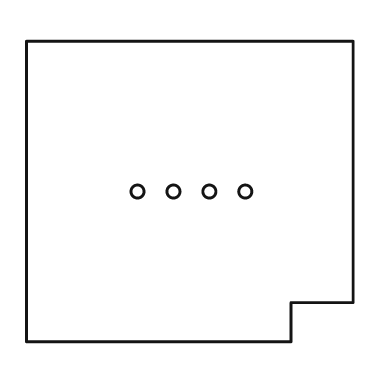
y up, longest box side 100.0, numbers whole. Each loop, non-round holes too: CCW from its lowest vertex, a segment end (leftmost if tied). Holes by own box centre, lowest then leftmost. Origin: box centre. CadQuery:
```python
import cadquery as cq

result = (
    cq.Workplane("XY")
    .moveTo(-50.0, -46.0)
    .lineTo(31.0, -46.0)
    .lineTo(31.0, -34.0)
    .lineTo(50.0, -34.0)
    .lineTo(50.0, 46.0)
    .lineTo(-50.0, 46.0)
    .close()
    .moveTo(-16.0, 0.0)
    .circle(2.0)
    .moveTo(-5.0, 0.0)
    .circle(2.0)
    .moveTo(6.0, 0.0)
    .circle(2.0)
    .moveTo(17.0, 0.0)
    .circle(2.0)
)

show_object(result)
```